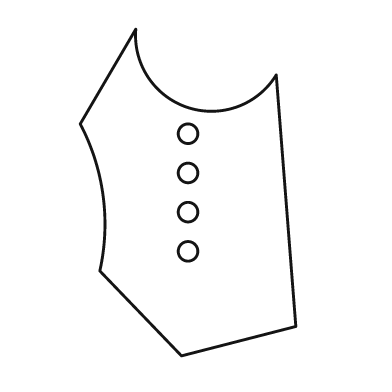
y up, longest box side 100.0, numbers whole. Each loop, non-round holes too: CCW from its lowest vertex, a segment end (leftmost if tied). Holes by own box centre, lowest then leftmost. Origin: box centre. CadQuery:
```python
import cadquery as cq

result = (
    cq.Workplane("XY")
    .moveTo(-2.0, -50.0)
    .lineTo(33.0, -41.0)
    .lineTo(27.0, 36.0)
    .threePointArc((0.0, 26.0), (-16.0, 50.0))
    .lineTo(-33.0, 21.0)
    .threePointArc((-26.0, -1.0), (-27.0, -24.0))
    .close()
    .moveTo(0.0, -18.0)
    .circle(3.0)
    .moveTo(0.0, -6.0)
    .circle(3.0)
    .moveTo(0.0, 6.0)
    .circle(3.0)
    .moveTo(0.0, 18.0)
    .circle(3.0)
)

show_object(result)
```